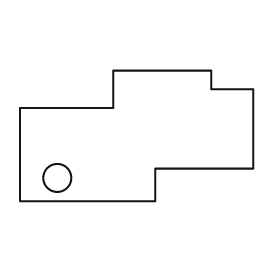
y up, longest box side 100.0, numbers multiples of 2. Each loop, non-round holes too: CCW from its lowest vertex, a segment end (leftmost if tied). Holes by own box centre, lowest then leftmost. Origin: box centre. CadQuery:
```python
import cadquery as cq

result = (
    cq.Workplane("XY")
    .moveTo(-50.0, -28.0)
    .lineTo(8.0, -28.0)
    .lineTo(8.0, -14.0)
    .lineTo(50.0, -14.0)
    .lineTo(50.0, 20.0)
    .lineTo(32.0, 20.0)
    .lineTo(32.0, 28.0)
    .lineTo(-10.0, 28.0)
    .lineTo(-10.0, 12.0)
    .lineTo(-50.0, 12.0)
    .close()
    .moveTo(-34.0, -18.0)
    .circle(6.0)
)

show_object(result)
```